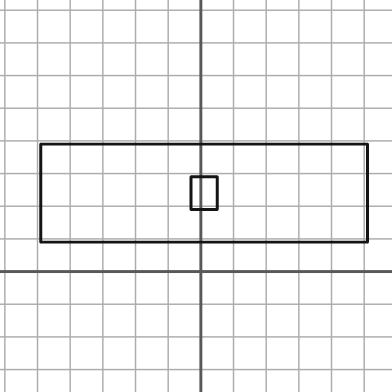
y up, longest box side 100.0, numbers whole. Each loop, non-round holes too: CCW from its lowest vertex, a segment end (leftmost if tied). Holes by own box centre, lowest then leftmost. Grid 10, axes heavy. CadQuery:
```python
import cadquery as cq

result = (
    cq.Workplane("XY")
    .moveTo(-49.0, 9.0)
    .lineTo(51.0, 9.0)
    .lineTo(51.0, 39.0)
    .lineTo(-49.0, 39.0)
    .close()
    .moveTo(-3.0, 19.0)
    .lineTo(5.0, 19.0)
    .lineTo(5.0, 29.0)
    .lineTo(-3.0, 29.0)
    .close()
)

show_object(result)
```